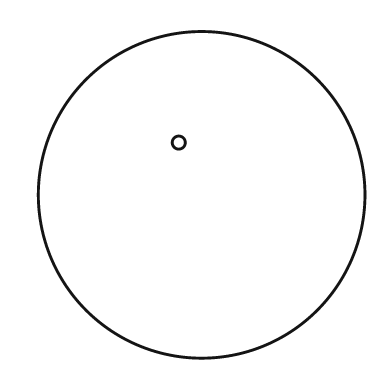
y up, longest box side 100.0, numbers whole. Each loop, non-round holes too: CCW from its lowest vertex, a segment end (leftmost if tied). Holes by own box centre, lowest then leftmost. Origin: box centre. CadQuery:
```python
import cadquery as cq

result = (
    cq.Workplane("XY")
    .moveTo(0.0, 0.0)
    .circle(50.0)
    .moveTo(-7.0, 16.0)
    .circle(2.0)
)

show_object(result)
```